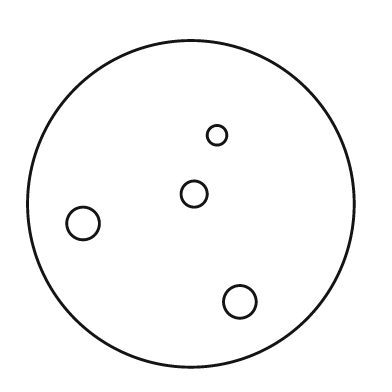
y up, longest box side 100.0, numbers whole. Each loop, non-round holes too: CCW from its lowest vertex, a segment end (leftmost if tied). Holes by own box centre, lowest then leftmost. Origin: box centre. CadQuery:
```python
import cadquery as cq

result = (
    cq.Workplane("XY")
    .moveTo(0.0, 0.0)
    .circle(50.0)
    .moveTo(15.0, -30.0)
    .circle(5.0)
    .moveTo(-33.0, -6.0)
    .circle(5.0)
    .moveTo(1.0, 3.0)
    .circle(4.0)
    .moveTo(8.0, 21.0)
    .circle(3.0)
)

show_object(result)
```